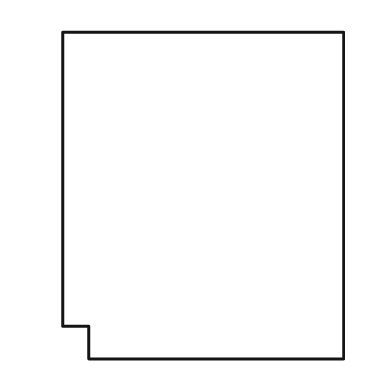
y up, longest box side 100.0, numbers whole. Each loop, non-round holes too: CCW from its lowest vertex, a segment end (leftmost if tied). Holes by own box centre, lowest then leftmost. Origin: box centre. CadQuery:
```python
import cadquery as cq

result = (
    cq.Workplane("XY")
    .moveTo(-35.0, -50.0)
    .lineTo(43.0, -50.0)
    .lineTo(43.0, 50.0)
    .lineTo(-43.0, 50.0)
    .lineTo(-43.0, -40.0)
    .lineTo(-35.0, -40.0)
    .close()
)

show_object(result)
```